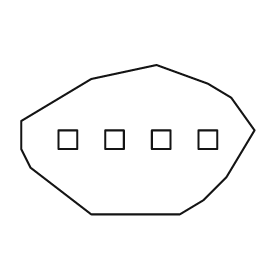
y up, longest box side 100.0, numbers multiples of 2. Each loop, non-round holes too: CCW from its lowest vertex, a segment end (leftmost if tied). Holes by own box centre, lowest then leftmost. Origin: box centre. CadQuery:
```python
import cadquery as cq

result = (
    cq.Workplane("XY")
    .moveTo(-20.0, -32.0)
    .lineTo(18.0, -32.0)
    .lineTo(28.0, -26.0)
    .lineTo(38.0, -16.0)
    .lineTo(50.0, 4.0)
    .lineTo(40.0, 18.0)
    .lineTo(30.0, 24.0)
    .lineTo(8.0, 32.0)
    .lineTo(-20.0, 26.0)
    .lineTo(-50.0, 8.0)
    .lineTo(-50.0, -4.0)
    .lineTo(-46.0, -12.0)
    .close()
    .moveTo(-34.0, -4.0)
    .lineTo(-26.0, -4.0)
    .lineTo(-26.0, 4.0)
    .lineTo(-34.0, 4.0)
    .close()
    .moveTo(-14.0, -4.0)
    .lineTo(-6.0, -4.0)
    .lineTo(-6.0, 4.0)
    .lineTo(-14.0, 4.0)
    .close()
    .moveTo(6.0, -4.0)
    .lineTo(14.0, -4.0)
    .lineTo(14.0, 4.0)
    .lineTo(6.0, 4.0)
    .close()
    .moveTo(26.0, -4.0)
    .lineTo(34.0, -4.0)
    .lineTo(34.0, 4.0)
    .lineTo(26.0, 4.0)
    .close()
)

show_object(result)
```